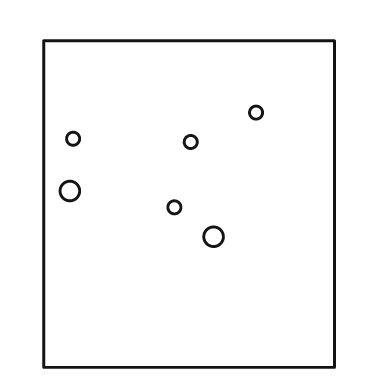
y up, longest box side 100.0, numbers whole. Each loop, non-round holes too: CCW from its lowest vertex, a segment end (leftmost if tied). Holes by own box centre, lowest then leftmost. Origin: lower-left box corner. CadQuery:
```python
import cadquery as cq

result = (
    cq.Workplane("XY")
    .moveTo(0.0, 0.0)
    .lineTo(89.0, 0.0)
    .lineTo(89.0, 100.0)
    .lineTo(0.0, 100.0)
    .close()
    .moveTo(52.0, 40.0)
    .circle(3.0)
    .moveTo(40.0, 49.0)
    .circle(2.0)
    .moveTo(8.0, 54.0)
    .circle(3.0)
    .moveTo(45.0, 69.0)
    .circle(2.0)
    .moveTo(9.0, 70.0)
    .circle(2.0)
    .moveTo(65.0, 78.0)
    .circle(2.0)
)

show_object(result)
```